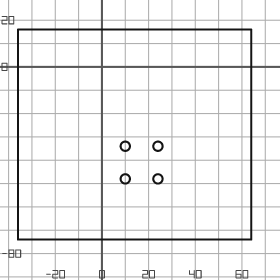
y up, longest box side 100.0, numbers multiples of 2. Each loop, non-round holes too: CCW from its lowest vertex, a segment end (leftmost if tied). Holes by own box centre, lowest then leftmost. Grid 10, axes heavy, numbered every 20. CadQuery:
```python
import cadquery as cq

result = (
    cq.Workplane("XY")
    .moveTo(-36.0, -74.0)
    .lineTo(64.0, -74.0)
    .lineTo(64.0, 16.0)
    .lineTo(-36.0, 16.0)
    .close()
    .moveTo(10.0, -48.0)
    .circle(2.0)
    .moveTo(24.0, -48.0)
    .circle(2.0)
    .moveTo(10.0, -34.0)
    .circle(2.0)
    .moveTo(24.0, -34.0)
    .circle(2.0)
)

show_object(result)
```